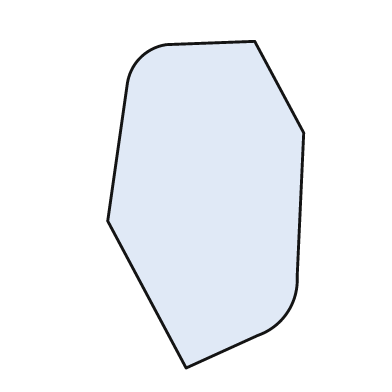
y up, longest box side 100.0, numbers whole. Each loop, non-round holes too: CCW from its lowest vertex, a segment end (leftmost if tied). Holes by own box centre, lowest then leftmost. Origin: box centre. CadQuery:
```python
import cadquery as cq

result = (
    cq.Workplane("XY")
    .moveTo(-6.0, -50.0)
    .lineTo(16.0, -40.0)
    .threePointArc((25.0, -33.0), (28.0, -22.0))
    .lineTo(30.0, 22.0)
    .lineTo(15.0, 50.0)
    .lineTo(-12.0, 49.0)
    .threePointArc((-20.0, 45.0), (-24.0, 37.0))
    .lineTo(-30.0, -5.0)
    .close()
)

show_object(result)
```